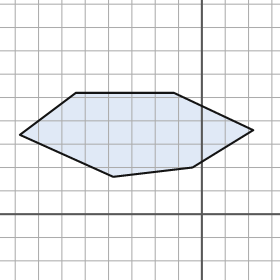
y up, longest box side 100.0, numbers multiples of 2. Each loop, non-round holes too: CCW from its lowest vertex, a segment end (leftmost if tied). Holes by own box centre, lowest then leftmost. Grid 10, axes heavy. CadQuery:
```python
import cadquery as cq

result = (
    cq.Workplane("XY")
    .moveTo(-38.0, 16.0)
    .lineTo(-4.0, 20.0)
    .lineTo(22.0, 36.0)
    .lineTo(-12.0, 52.0)
    .lineTo(-54.0, 52.0)
    .lineTo(-78.0, 34.0)
    .close()
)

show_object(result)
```